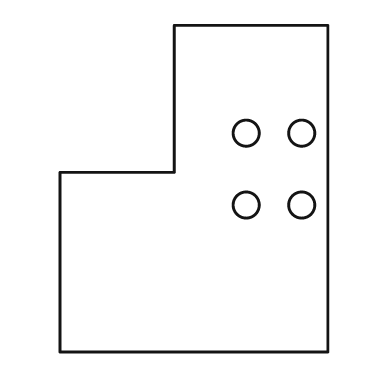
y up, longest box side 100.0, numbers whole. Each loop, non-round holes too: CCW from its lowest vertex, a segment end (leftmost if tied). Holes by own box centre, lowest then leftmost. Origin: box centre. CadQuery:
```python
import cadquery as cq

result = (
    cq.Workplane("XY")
    .moveTo(-41.0, -50.0)
    .lineTo(41.0, -50.0)
    .lineTo(41.0, 50.0)
    .lineTo(-6.0, 50.0)
    .lineTo(-6.0, 5.0)
    .lineTo(-41.0, 5.0)
    .close()
    .moveTo(16.0, -5.0)
    .circle(4.0)
    .moveTo(33.0, -5.0)
    .circle(4.0)
    .moveTo(16.0, 17.0)
    .circle(4.0)
    .moveTo(33.0, 17.0)
    .circle(4.0)
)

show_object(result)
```